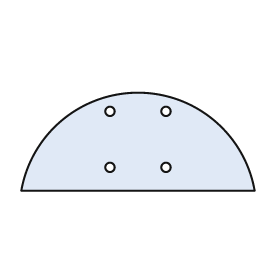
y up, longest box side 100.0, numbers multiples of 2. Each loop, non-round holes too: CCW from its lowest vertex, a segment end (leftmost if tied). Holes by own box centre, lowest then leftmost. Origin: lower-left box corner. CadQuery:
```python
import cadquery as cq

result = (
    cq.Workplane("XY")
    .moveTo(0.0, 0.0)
    .lineTo(100.0, 0.0)
    .threePointArc((50.0, 42.0), (0.0, 0.0))
    .close()
    .moveTo(38.0, 10.0)
    .circle(2.0)
    .moveTo(62.0, 10.0)
    .circle(2.0)
    .moveTo(38.0, 34.0)
    .circle(2.0)
    .moveTo(62.0, 34.0)
    .circle(2.0)
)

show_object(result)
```